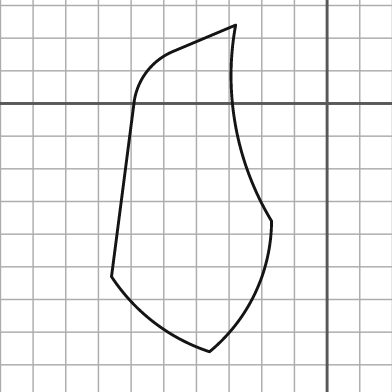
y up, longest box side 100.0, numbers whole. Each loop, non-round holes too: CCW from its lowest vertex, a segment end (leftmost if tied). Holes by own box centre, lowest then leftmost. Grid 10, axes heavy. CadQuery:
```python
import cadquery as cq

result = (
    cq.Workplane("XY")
    .moveTo(-36.0, -76.0)
    .threePointArc((-22.0, -58.0), (-17.0, -36.0))
    .threePointArc((-28.0, -7.0), (-28.0, 24.0))
    .lineTo(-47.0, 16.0)
    .threePointArc((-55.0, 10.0), (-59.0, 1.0))
    .lineTo(-66.0, -53.0)
    .threePointArc((-53.0, -67.0), (-36.0, -76.0))
    .close()
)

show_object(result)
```